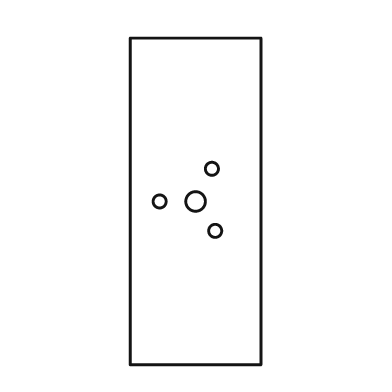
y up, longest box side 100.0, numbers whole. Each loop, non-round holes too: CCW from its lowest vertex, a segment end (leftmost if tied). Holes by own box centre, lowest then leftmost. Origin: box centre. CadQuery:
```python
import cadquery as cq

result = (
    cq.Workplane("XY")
    .moveTo(-20.0, -50.0)
    .lineTo(20.0, -50.0)
    .lineTo(20.0, 50.0)
    .lineTo(-20.0, 50.0)
    .close()
    .moveTo(6.0, -9.0)
    .circle(2.0)
    .moveTo(-11.0, 0.0)
    .circle(2.0)
    .moveTo(0.0, 0.0)
    .circle(3.0)
    .moveTo(5.0, 10.0)
    .circle(2.0)
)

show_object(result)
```